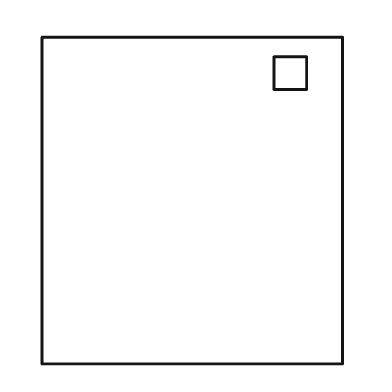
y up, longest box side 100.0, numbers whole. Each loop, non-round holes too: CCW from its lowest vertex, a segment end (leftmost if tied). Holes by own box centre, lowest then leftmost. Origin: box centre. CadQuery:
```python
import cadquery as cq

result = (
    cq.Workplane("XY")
    .moveTo(-46.0, -50.0)
    .lineTo(46.0, -50.0)
    .lineTo(46.0, 50.0)
    .lineTo(-46.0, 50.0)
    .close()
    .moveTo(25.0, 34.0)
    .lineTo(35.0, 34.0)
    .lineTo(35.0, 44.0)
    .lineTo(25.0, 44.0)
    .close()
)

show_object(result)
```